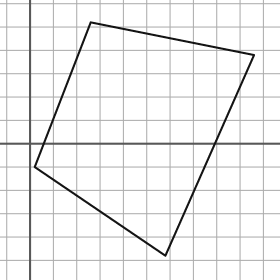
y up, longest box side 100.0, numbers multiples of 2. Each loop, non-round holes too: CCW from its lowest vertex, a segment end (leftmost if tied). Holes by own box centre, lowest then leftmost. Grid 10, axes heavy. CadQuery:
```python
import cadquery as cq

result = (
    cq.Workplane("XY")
    .moveTo(58.0, -48.0)
    .lineTo(96.0, 38.0)
    .lineTo(26.0, 52.0)
    .lineTo(2.0, -10.0)
    .close()
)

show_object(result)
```